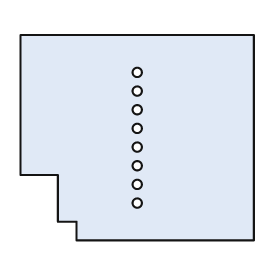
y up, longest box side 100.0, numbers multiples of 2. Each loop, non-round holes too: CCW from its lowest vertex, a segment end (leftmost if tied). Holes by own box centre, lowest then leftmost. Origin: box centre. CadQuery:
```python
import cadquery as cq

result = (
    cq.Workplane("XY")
    .moveTo(-26.0, -44.0)
    .lineTo(50.0, -44.0)
    .lineTo(50.0, 44.0)
    .lineTo(-50.0, 44.0)
    .lineTo(-50.0, -16.0)
    .lineTo(-34.0, -16.0)
    .lineTo(-34.0, -36.0)
    .lineTo(-26.0, -36.0)
    .close()
    .moveTo(0.0, -28.0)
    .circle(2.0)
    .moveTo(0.0, -20.0)
    .circle(2.0)
    .moveTo(0.0, -12.0)
    .circle(2.0)
    .moveTo(0.0, -4.0)
    .circle(2.0)
    .moveTo(0.0, 4.0)
    .circle(2.0)
    .moveTo(0.0, 12.0)
    .circle(2.0)
    .moveTo(0.0, 20.0)
    .circle(2.0)
    .moveTo(0.0, 28.0)
    .circle(2.0)
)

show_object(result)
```